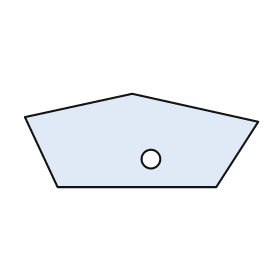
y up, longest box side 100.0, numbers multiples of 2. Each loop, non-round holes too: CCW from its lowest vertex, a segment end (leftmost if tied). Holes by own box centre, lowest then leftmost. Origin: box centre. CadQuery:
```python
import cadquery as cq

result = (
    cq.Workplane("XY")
    .moveTo(-36.0, -20.0)
    .lineTo(32.0, -20.0)
    .lineTo(50.0, 8.0)
    .lineTo(-4.0, 20.0)
    .lineTo(-50.0, 10.0)
    .close()
    .moveTo(4.0, -8.0)
    .circle(4.0)
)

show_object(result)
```